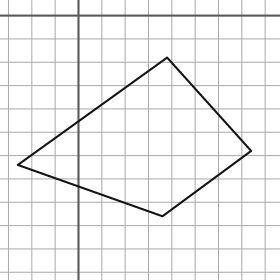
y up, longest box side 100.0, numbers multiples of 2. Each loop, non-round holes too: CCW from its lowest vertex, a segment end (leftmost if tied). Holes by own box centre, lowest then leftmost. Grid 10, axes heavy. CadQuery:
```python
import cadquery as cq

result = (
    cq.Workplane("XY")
    .moveTo(36.0, -86.0)
    .lineTo(74.0, -58.0)
    .lineTo(38.0, -18.0)
    .lineTo(-26.0, -64.0)
    .close()
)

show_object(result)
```